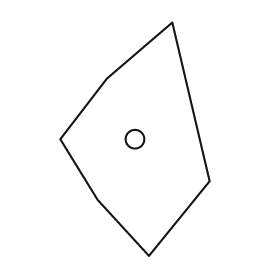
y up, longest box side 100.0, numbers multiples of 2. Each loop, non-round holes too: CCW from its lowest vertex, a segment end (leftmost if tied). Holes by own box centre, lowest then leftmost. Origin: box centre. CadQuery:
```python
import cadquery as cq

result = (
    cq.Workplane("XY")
    .moveTo(6.0, -50.0)
    .lineTo(32.0, -18.0)
    .lineTo(16.0, 50.0)
    .lineTo(-12.0, 26.0)
    .lineTo(-32.0, 0.0)
    .lineTo(-16.0, -26.0)
    .close()
    .moveTo(0.0, 0.0)
    .circle(4.0)
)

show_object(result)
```